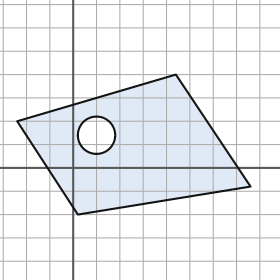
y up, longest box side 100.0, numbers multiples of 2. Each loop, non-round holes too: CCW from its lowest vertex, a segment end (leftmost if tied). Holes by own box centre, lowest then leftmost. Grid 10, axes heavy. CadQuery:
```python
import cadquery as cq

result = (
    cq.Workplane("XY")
    .moveTo(2.0, -20.0)
    .lineTo(76.0, -8.0)
    .lineTo(44.0, 40.0)
    .lineTo(-24.0, 20.0)
    .close()
    .moveTo(10.0, 14.0)
    .circle(8.0)
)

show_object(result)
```